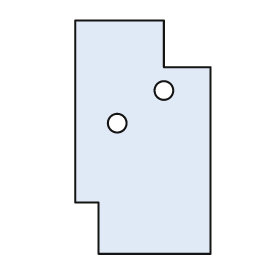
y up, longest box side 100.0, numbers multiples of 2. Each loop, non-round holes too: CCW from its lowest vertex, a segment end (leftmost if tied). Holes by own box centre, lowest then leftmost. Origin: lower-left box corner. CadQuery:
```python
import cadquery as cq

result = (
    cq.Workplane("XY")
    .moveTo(10.0, 0.0)
    .lineTo(58.0, 0.0)
    .lineTo(58.0, 80.0)
    .lineTo(38.0, 80.0)
    .lineTo(38.0, 100.0)
    .lineTo(0.0, 100.0)
    .lineTo(0.0, 22.0)
    .lineTo(10.0, 22.0)
    .close()
    .moveTo(18.0, 56.0)
    .circle(4.0)
    .moveTo(38.0, 70.0)
    .circle(4.0)
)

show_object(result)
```